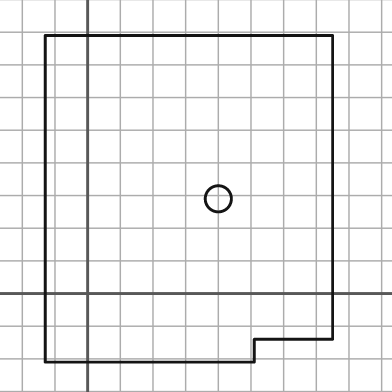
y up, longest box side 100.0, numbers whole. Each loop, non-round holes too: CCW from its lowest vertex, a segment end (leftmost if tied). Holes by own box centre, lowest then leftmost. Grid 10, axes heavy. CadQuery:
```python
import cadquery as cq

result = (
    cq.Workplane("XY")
    .moveTo(-13.0, -21.0)
    .lineTo(51.0, -21.0)
    .lineTo(51.0, -14.0)
    .lineTo(75.0, -14.0)
    .lineTo(75.0, 79.0)
    .lineTo(-13.0, 79.0)
    .close()
    .moveTo(40.0, 29.0)
    .circle(4.0)
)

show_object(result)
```